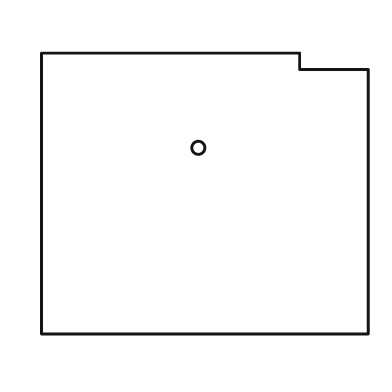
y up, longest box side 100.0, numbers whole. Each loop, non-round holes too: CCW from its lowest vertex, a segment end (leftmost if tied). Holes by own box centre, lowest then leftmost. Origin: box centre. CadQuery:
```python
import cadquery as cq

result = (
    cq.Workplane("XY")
    .moveTo(-50.0, -43.0)
    .lineTo(50.0, -43.0)
    .lineTo(50.0, 38.0)
    .lineTo(29.0, 38.0)
    .lineTo(29.0, 43.0)
    .lineTo(-50.0, 43.0)
    .close()
    .moveTo(-2.0, 14.0)
    .circle(2.0)
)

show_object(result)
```